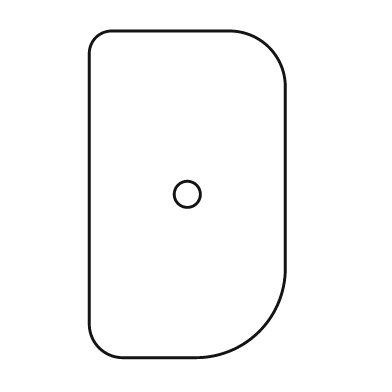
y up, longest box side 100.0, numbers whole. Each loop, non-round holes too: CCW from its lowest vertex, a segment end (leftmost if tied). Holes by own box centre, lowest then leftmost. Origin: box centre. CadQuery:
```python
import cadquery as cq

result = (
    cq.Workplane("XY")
    .moveTo(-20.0, -50.0)
    .lineTo(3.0, -50.0)
    .threePointArc((22.0, -42.0), (30.0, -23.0))
    .lineTo(30.0, 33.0)
    .threePointArc((25.0, 45.0), (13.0, 50.0))
    .lineTo(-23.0, 50.0)
    .threePointArc((-28.0, 48.0), (-30.0, 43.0))
    .lineTo(-30.0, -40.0)
    .threePointArc((-27.0, -47.0), (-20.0, -50.0))
    .close()
    .moveTo(0.0, 0.0)
    .circle(4.0)
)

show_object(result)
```